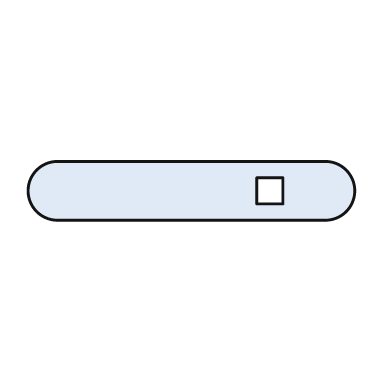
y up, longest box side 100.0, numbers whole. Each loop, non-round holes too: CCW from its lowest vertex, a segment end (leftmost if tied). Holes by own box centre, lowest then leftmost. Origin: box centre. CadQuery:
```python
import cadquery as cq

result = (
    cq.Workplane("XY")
    .moveTo(-41.0, -9.0)
    .lineTo(41.0, -9.0)
    .threePointArc((50.0, 0.0), (41.0, 9.0))
    .lineTo(-41.0, 9.0)
    .threePointArc((-50.0, 0.0), (-41.0, -9.0))
    .close()
    .moveTo(20.0, -4.0)
    .lineTo(28.0, -4.0)
    .lineTo(28.0, 4.0)
    .lineTo(20.0, 4.0)
    .close()
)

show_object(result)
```